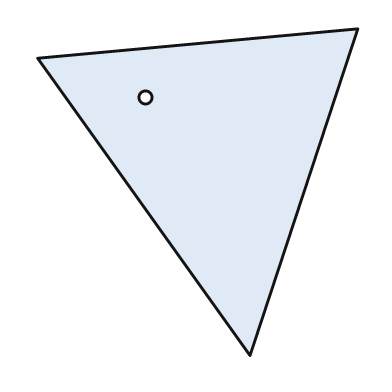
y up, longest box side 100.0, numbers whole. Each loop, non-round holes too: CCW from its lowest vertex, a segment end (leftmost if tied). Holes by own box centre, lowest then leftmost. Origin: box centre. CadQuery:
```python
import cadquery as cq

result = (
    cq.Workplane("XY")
    .moveTo(16.0, -50.0)
    .lineTo(49.0, 50.0)
    .lineTo(-49.0, 41.0)
    .close()
    .moveTo(-16.0, 29.0)
    .circle(2.0)
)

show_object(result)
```